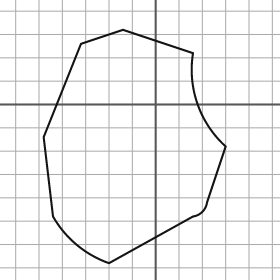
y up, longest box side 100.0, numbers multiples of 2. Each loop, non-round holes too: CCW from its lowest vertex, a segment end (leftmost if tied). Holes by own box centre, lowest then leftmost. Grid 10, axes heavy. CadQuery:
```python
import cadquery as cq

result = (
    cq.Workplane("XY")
    .moveTo(-20.0, -68.0)
    .lineTo(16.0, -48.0)
    .threePointArc((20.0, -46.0), (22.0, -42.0))
    .lineTo(30.0, -18.0)
    .threePointArc((18.0, 0.0), (16.0, 22.0))
    .lineTo(-14.0, 32.0)
    .lineTo(-32.0, 26.0)
    .lineTo(-48.0, -14.0)
    .lineTo(-44.0, -48.0)
    .threePointArc((-34.0, -60.0), (-20.0, -68.0))
    .close()
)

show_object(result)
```